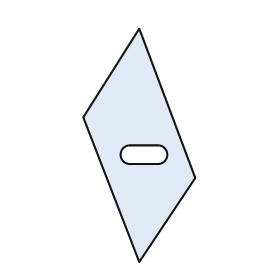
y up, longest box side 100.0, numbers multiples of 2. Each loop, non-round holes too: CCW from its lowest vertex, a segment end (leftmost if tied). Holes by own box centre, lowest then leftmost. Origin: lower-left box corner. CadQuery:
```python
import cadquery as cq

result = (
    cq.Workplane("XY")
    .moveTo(24.0, 0.0)
    .lineTo(48.0, 36.0)
    .lineTo(24.0, 100.0)
    .lineTo(0.0, 62.0)
    .close()
    .moveTo(20.0, 42.0)
    .lineTo(32.0, 42.0)
    .threePointArc((36.0, 46.0), (32.0, 50.0))
    .lineTo(20.0, 50.0)
    .threePointArc((16.0, 46.0), (20.0, 42.0))
    .close()
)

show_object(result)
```